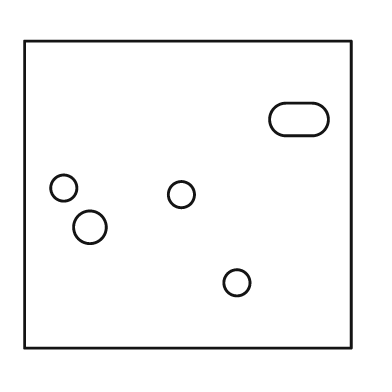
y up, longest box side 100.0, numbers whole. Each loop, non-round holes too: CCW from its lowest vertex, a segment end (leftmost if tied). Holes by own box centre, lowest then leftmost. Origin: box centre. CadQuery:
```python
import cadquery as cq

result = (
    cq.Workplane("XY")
    .moveTo(-50.0, -47.0)
    .lineTo(50.0, -47.0)
    .lineTo(50.0, 47.0)
    .lineTo(-50.0, 47.0)
    .close()
    .moveTo(15.0, -27.0)
    .circle(4.0)
    .moveTo(-30.0, -10.0)
    .circle(5.0)
    .moveTo(-2.0, 0.0)
    .circle(4.0)
    .moveTo(-38.0, 2.0)
    .circle(4.0)
    .moveTo(30.0, 18.0)
    .lineTo(38.0, 18.0)
    .threePointArc((43.0, 23.0), (38.0, 28.0))
    .lineTo(30.0, 28.0)
    .threePointArc((25.0, 23.0), (30.0, 18.0))
    .close()
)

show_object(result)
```